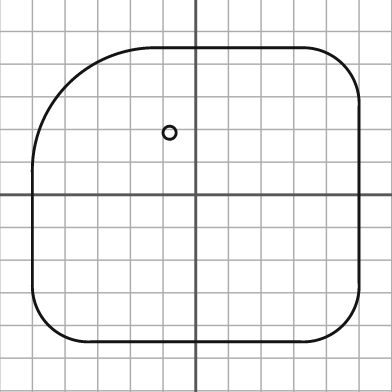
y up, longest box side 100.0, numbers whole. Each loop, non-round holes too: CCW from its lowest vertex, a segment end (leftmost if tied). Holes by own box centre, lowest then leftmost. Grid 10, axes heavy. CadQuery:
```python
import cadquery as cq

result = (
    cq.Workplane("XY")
    .moveTo(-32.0, -45.0)
    .lineTo(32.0, -45.0)
    .threePointArc((45.0, -40.0), (50.0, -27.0))
    .lineTo(50.0, 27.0)
    .threePointArc((45.0, 40.0), (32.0, 45.0))
    .lineTo(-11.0, 45.0)
    .threePointArc((-39.0, 34.0), (-50.0, 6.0))
    .lineTo(-50.0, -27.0)
    .threePointArc((-45.0, -40.0), (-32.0, -45.0))
    .close()
    .moveTo(-8.0, 19.0)
    .circle(2.0)
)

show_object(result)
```